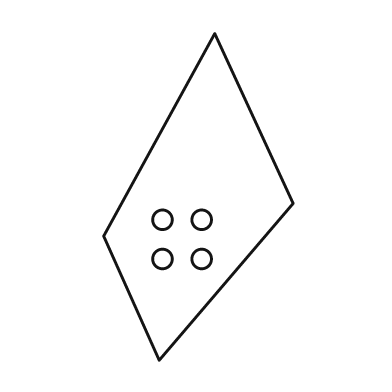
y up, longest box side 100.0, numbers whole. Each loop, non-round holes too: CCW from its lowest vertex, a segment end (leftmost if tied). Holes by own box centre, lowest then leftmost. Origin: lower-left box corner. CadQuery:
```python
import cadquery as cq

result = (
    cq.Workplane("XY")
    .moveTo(17.0, 0.0)
    .lineTo(58.0, 48.0)
    .lineTo(34.0, 100.0)
    .lineTo(0.0, 38.0)
    .close()
    .moveTo(18.0, 31.0)
    .circle(3.0)
    .moveTo(30.0, 31.0)
    .circle(3.0)
    .moveTo(18.0, 43.0)
    .circle(3.0)
    .moveTo(30.0, 43.0)
    .circle(3.0)
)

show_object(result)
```